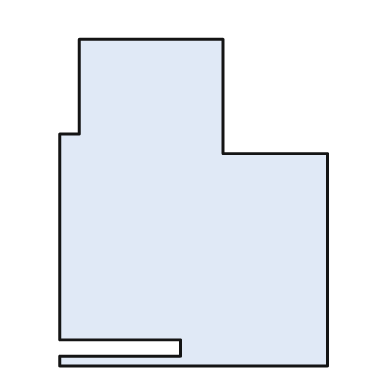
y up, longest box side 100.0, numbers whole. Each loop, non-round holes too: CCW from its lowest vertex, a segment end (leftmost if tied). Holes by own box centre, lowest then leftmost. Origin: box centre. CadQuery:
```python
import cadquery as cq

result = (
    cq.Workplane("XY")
    .moveTo(-41.0, -50.0)
    .lineTo(41.0, -50.0)
    .lineTo(41.0, 15.0)
    .lineTo(9.0, 15.0)
    .lineTo(9.0, 50.0)
    .lineTo(-35.0, 50.0)
    .lineTo(-35.0, 21.0)
    .lineTo(-41.0, 21.0)
    .lineTo(-41.0, -42.0)
    .lineTo(-4.0, -42.0)
    .lineTo(-4.0, -47.0)
    .lineTo(-41.0, -47.0)
    .close()
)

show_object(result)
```